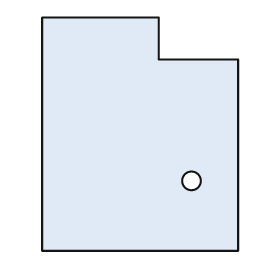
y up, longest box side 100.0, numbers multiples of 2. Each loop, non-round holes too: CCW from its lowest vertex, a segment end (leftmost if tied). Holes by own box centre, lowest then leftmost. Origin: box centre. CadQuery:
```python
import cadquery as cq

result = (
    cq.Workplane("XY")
    .moveTo(-42.0, -50.0)
    .lineTo(42.0, -50.0)
    .lineTo(42.0, 32.0)
    .lineTo(8.0, 32.0)
    .lineTo(8.0, 50.0)
    .lineTo(-42.0, 50.0)
    .close()
    .moveTo(22.0, -20.0)
    .circle(4.0)
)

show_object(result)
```